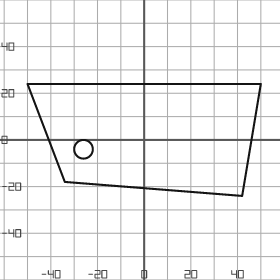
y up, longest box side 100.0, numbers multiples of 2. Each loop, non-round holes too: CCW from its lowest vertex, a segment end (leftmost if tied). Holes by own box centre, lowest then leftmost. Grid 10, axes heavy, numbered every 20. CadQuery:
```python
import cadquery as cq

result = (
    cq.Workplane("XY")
    .moveTo(42.0, -24.0)
    .lineTo(50.0, 24.0)
    .lineTo(-50.0, 24.0)
    .lineTo(-34.0, -18.0)
    .close()
    .moveTo(-26.0, -4.0)
    .circle(4.0)
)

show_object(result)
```